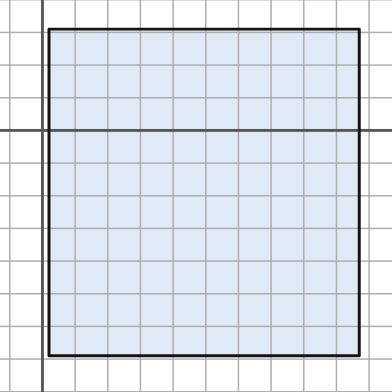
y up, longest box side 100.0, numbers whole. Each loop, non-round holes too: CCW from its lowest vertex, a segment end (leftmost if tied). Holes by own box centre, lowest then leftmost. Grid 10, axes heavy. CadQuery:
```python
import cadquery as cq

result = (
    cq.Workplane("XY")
    .moveTo(2.0, -69.0)
    .lineTo(97.0, -69.0)
    .lineTo(97.0, 31.0)
    .lineTo(2.0, 31.0)
    .close()
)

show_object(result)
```